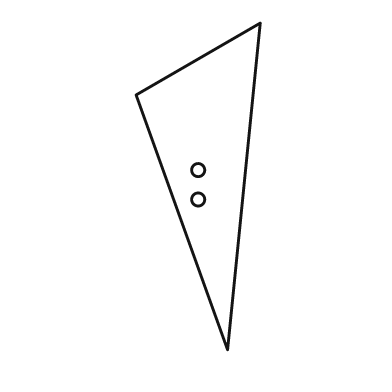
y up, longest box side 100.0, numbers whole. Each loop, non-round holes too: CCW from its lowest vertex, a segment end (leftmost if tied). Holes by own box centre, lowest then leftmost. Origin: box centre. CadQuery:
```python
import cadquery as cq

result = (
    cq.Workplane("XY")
    .moveTo(9.0, -50.0)
    .lineTo(19.0, 50.0)
    .lineTo(-19.0, 28.0)
    .close()
    .moveTo(0.0, -4.0)
    .circle(2.0)
    .moveTo(0.0, 5.0)
    .circle(2.0)
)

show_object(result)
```